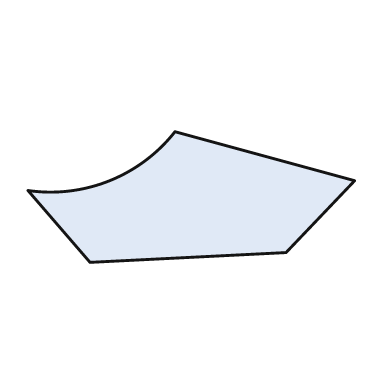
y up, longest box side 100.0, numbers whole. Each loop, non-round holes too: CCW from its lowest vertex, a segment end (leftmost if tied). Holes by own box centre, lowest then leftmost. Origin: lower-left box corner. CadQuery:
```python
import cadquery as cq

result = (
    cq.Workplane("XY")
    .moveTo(19.0, 0.0)
    .lineTo(79.0, 3.0)
    .lineTo(100.0, 25.0)
    .lineTo(45.0, 40.0)
    .threePointArc((25.0, 25.0), (0.0, 22.0))
    .close()
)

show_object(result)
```